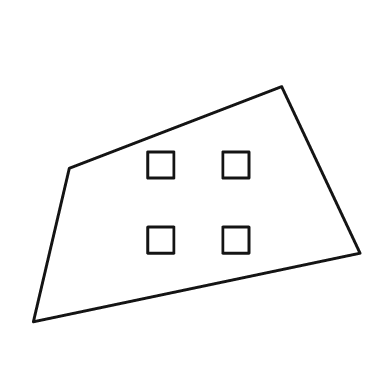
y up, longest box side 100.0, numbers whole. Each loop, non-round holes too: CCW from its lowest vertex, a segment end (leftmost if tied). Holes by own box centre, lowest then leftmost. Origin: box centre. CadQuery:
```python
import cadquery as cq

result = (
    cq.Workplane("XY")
    .moveTo(-50.0, -36.0)
    .lineTo(50.0, -15.0)
    .lineTo(26.0, 36.0)
    .lineTo(-39.0, 11.0)
    .close()
    .moveTo(-15.0, -15.0)
    .lineTo(-7.0, -15.0)
    .lineTo(-7.0, -7.0)
    .lineTo(-15.0, -7.0)
    .close()
    .moveTo(8.0, -15.0)
    .lineTo(16.0, -15.0)
    .lineTo(16.0, -7.0)
    .lineTo(8.0, -7.0)
    .close()
    .moveTo(-15.0, 8.0)
    .lineTo(-7.0, 8.0)
    .lineTo(-7.0, 16.0)
    .lineTo(-15.0, 16.0)
    .close()
    .moveTo(8.0, 8.0)
    .lineTo(16.0, 8.0)
    .lineTo(16.0, 16.0)
    .lineTo(8.0, 16.0)
    .close()
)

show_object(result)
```